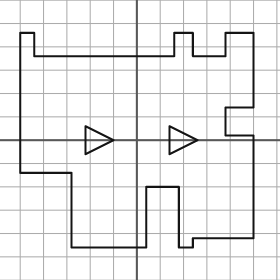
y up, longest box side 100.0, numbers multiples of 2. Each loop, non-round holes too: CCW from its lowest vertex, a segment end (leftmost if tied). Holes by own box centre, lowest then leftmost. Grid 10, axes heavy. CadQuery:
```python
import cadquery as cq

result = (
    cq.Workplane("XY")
    .moveTo(-28.0, -46.0)
    .lineTo(4.0, -46.0)
    .lineTo(4.0, -20.0)
    .lineTo(18.0, -20.0)
    .lineTo(18.0, -46.0)
    .lineTo(24.0, -46.0)
    .lineTo(24.0, -42.0)
    .lineTo(50.0, -42.0)
    .lineTo(50.0, 2.0)
    .lineTo(38.0, 2.0)
    .lineTo(38.0, 14.0)
    .lineTo(50.0, 14.0)
    .lineTo(50.0, 46.0)
    .lineTo(38.0, 46.0)
    .lineTo(38.0, 36.0)
    .lineTo(24.0, 36.0)
    .lineTo(24.0, 46.0)
    .lineTo(16.0, 46.0)
    .lineTo(16.0, 36.0)
    .lineTo(-44.0, 36.0)
    .lineTo(-44.0, 46.0)
    .lineTo(-50.0, 46.0)
    .lineTo(-50.0, -14.0)
    .lineTo(-28.0, -14.0)
    .close()
    .moveTo(-22.0, -6.0)
    .lineTo(-10.0, 0.0)
    .lineTo(-22.0, 6.0)
    .close()
    .moveTo(14.0, -6.0)
    .lineTo(26.0, 0.0)
    .lineTo(14.0, 6.0)
    .close()
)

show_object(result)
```